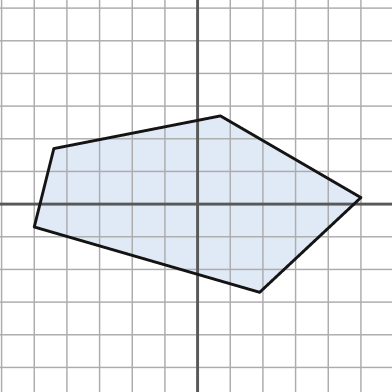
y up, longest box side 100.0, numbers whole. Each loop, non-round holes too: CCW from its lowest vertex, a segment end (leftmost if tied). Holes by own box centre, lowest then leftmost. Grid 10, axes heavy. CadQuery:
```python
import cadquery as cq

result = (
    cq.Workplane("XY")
    .moveTo(19.0, -27.0)
    .lineTo(50.0, 2.0)
    .lineTo(7.0, 27.0)
    .lineTo(-44.0, 17.0)
    .lineTo(-50.0, -7.0)
    .close()
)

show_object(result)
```